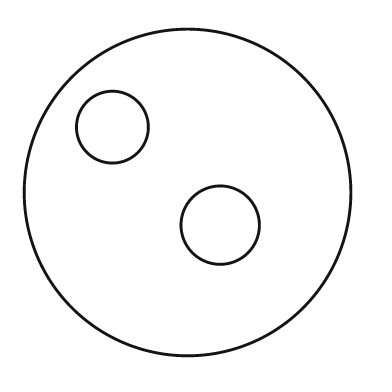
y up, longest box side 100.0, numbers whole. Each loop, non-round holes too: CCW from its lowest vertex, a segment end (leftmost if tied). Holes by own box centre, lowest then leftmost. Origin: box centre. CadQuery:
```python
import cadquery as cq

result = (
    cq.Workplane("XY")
    .moveTo(0.0, 0.0)
    .circle(50.0)
    .moveTo(10.0, -10.0)
    .circle(12.0)
    .moveTo(-23.0, 20.0)
    .circle(11.0)
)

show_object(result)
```